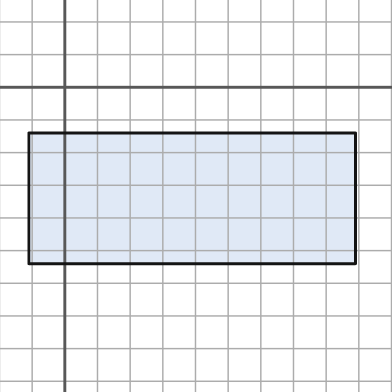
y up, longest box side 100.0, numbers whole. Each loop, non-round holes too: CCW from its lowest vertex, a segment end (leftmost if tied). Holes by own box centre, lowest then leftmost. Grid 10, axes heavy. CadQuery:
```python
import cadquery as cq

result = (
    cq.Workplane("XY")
    .moveTo(-11.0, -54.0)
    .lineTo(89.0, -54.0)
    .lineTo(89.0, -14.0)
    .lineTo(-11.0, -14.0)
    .close()
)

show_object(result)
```